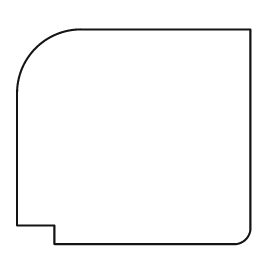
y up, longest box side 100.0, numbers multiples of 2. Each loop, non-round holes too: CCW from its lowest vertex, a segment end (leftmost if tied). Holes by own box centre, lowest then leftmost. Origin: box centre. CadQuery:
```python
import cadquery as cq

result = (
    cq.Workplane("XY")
    .moveTo(-34.0, -46.0)
    .lineTo(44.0, -46.0)
    .threePointArc((48.0, -44.0), (50.0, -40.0))
    .lineTo(50.0, 46.0)
    .lineTo(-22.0, 46.0)
    .threePointArc((-42.0, 38.0), (-50.0, 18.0))
    .lineTo(-50.0, -38.0)
    .lineTo(-34.0, -38.0)
    .close()
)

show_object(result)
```